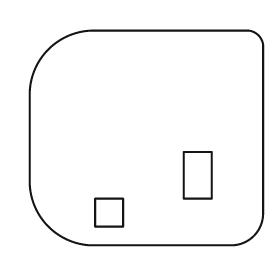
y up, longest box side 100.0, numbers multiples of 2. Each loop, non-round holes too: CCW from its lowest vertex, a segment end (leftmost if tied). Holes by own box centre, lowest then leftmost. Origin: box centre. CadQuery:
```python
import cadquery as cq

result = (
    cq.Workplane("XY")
    .moveTo(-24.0, -46.0)
    .lineTo(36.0, -46.0)
    .threePointArc((46.0, -42.0), (50.0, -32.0))
    .lineTo(50.0, 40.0)
    .threePointArc((48.0, 44.0), (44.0, 46.0))
    .lineTo(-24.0, 46.0)
    .threePointArc((-42.0, 38.0), (-50.0, 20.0))
    .lineTo(-50.0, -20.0)
    .threePointArc((-42.0, -38.0), (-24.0, -46.0))
    .close()
    .moveTo(-22.0, -38.0)
    .lineTo(-10.0, -38.0)
    .lineTo(-10.0, -26.0)
    .lineTo(-22.0, -26.0)
    .close()
    .moveTo(16.0, -26.0)
    .lineTo(28.0, -26.0)
    .lineTo(28.0, -6.0)
    .lineTo(16.0, -6.0)
    .close()
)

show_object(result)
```